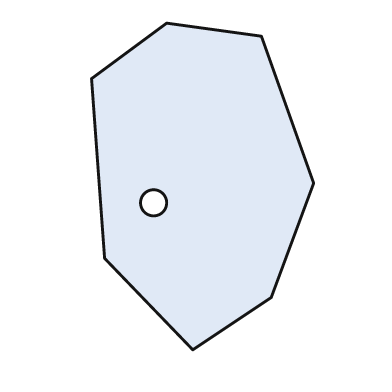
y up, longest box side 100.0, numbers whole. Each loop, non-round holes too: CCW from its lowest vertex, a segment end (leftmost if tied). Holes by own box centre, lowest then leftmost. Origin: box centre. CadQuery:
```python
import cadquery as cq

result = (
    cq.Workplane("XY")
    .moveTo(-3.0, -50.0)
    .lineTo(21.0, -34.0)
    .lineTo(34.0, 1.0)
    .lineTo(18.0, 46.0)
    .lineTo(-11.0, 50.0)
    .lineTo(-34.0, 33.0)
    .lineTo(-30.0, -22.0)
    .close()
    .moveTo(-15.0, -5.0)
    .circle(4.0)
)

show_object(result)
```